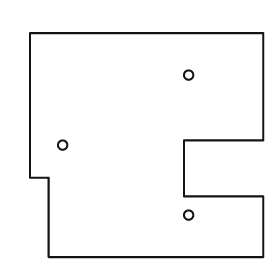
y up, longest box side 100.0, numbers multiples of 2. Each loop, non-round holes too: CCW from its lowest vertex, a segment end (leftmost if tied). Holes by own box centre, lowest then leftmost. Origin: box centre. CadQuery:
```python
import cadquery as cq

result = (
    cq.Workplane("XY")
    .moveTo(-42.0, -48.0)
    .lineTo(50.0, -48.0)
    .lineTo(50.0, -22.0)
    .lineTo(16.0, -22.0)
    .lineTo(16.0, 2.0)
    .lineTo(50.0, 2.0)
    .lineTo(50.0, 48.0)
    .lineTo(-50.0, 48.0)
    .lineTo(-50.0, -14.0)
    .lineTo(-42.0, -14.0)
    .close()
    .moveTo(18.0, -30.0)
    .circle(2.0)
    .moveTo(-36.0, 0.0)
    .circle(2.0)
    .moveTo(18.0, 30.0)
    .circle(2.0)
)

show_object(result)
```